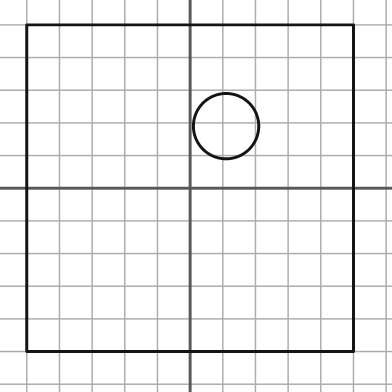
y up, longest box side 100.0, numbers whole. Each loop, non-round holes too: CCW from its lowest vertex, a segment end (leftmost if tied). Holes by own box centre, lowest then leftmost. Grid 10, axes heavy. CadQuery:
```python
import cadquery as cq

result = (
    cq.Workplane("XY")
    .moveTo(-50.0, -50.0)
    .lineTo(50.0, -50.0)
    .lineTo(50.0, 50.0)
    .lineTo(-50.0, 50.0)
    .close()
    .moveTo(11.0, 19.0)
    .circle(10.0)
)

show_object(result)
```